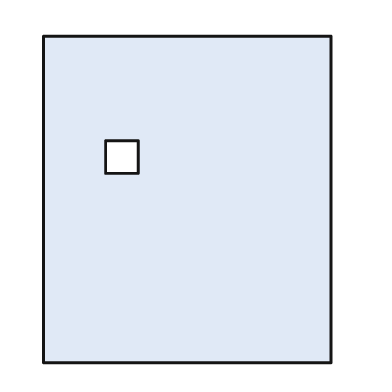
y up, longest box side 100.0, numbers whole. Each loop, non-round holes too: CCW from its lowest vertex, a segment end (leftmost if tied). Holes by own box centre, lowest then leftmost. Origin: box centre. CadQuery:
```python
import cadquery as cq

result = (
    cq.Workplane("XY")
    .moveTo(-44.0, -50.0)
    .lineTo(44.0, -50.0)
    .lineTo(44.0, 50.0)
    .lineTo(-44.0, 50.0)
    .close()
    .moveTo(-25.0, 8.0)
    .lineTo(-15.0, 8.0)
    .lineTo(-15.0, 18.0)
    .lineTo(-25.0, 18.0)
    .close()
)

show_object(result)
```